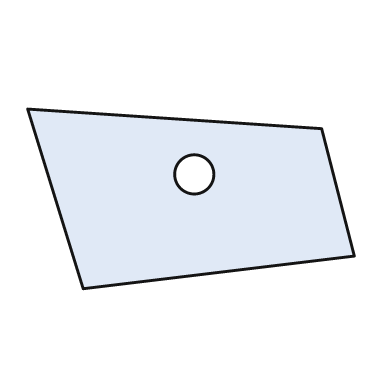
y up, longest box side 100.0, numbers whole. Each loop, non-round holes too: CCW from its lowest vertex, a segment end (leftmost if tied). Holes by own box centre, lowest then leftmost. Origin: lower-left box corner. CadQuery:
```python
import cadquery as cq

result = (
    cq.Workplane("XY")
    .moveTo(17.0, 0.0)
    .lineTo(100.0, 10.0)
    .lineTo(90.0, 49.0)
    .lineTo(0.0, 55.0)
    .close()
    .moveTo(51.0, 35.0)
    .circle(6.0)
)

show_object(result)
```